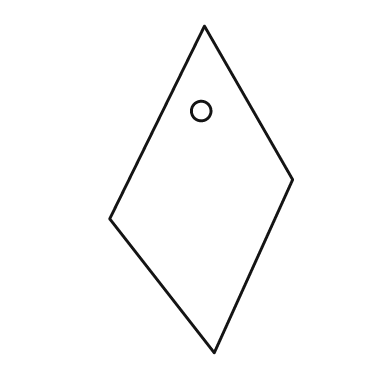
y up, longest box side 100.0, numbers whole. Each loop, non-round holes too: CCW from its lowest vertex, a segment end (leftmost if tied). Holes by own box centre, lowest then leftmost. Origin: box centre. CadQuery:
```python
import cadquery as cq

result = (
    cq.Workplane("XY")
    .moveTo(4.0, -50.0)
    .lineTo(28.0, 3.0)
    .lineTo(1.0, 50.0)
    .lineTo(-28.0, -9.0)
    .close()
    .moveTo(0.0, 24.0)
    .circle(3.0)
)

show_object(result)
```